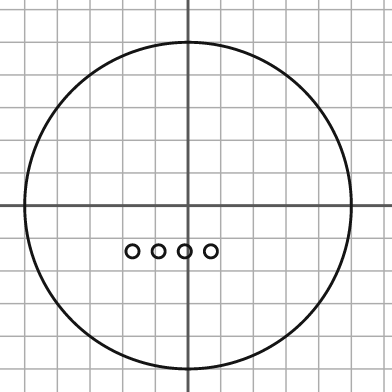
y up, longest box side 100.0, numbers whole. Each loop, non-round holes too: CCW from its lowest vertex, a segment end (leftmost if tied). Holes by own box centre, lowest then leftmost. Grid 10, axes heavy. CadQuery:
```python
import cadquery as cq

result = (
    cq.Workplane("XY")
    .moveTo(0.0, 0.0)
    .circle(50.0)
    .moveTo(-17.0, -14.0)
    .circle(2.0)
    .moveTo(-9.0, -14.0)
    .circle(2.0)
    .moveTo(-1.0, -14.0)
    .circle(2.0)
    .moveTo(7.0, -14.0)
    .circle(2.0)
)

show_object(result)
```